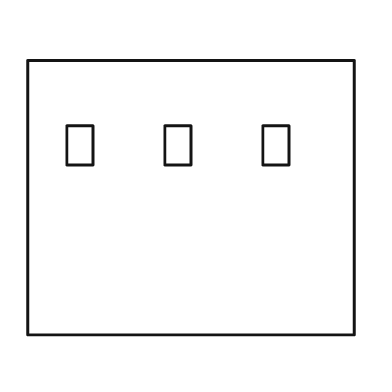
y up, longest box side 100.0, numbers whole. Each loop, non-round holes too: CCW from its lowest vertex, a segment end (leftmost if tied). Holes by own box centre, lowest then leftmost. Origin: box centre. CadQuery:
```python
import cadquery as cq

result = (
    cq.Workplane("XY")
    .moveTo(-50.0, -42.0)
    .lineTo(50.0, -42.0)
    .lineTo(50.0, 42.0)
    .lineTo(-50.0, 42.0)
    .close()
    .moveTo(-38.0, 10.0)
    .lineTo(-30.0, 10.0)
    .lineTo(-30.0, 22.0)
    .lineTo(-38.0, 22.0)
    .close()
    .moveTo(-8.0, 10.0)
    .lineTo(0.0, 10.0)
    .lineTo(0.0, 22.0)
    .lineTo(-8.0, 22.0)
    .close()
    .moveTo(22.0, 10.0)
    .lineTo(30.0, 10.0)
    .lineTo(30.0, 22.0)
    .lineTo(22.0, 22.0)
    .close()
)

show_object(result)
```